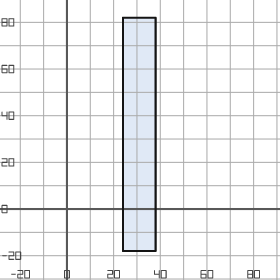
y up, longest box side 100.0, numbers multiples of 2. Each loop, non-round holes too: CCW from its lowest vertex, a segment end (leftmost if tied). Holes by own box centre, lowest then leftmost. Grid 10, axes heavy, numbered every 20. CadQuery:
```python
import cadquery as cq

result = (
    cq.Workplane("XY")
    .moveTo(24.0, -18.0)
    .lineTo(38.0, -18.0)
    .lineTo(38.0, 82.0)
    .lineTo(24.0, 82.0)
    .close()
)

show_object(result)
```